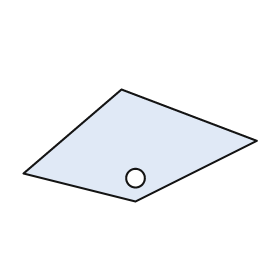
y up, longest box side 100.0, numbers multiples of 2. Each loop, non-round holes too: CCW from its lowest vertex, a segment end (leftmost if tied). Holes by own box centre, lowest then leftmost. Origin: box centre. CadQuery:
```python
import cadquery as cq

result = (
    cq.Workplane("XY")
    .moveTo(-2.0, -24.0)
    .lineTo(50.0, 2.0)
    .lineTo(-8.0, 24.0)
    .lineTo(-50.0, -12.0)
    .close()
    .moveTo(-2.0, -14.0)
    .circle(4.0)
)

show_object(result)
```